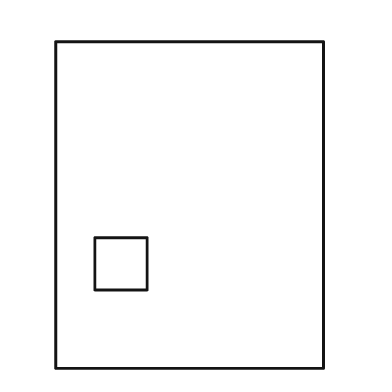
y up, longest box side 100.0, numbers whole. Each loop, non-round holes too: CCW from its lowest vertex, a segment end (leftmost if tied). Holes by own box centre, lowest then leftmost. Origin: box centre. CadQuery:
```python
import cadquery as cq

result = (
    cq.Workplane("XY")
    .moveTo(-41.0, -50.0)
    .lineTo(41.0, -50.0)
    .lineTo(41.0, 50.0)
    .lineTo(-41.0, 50.0)
    .close()
    .moveTo(-29.0, -26.0)
    .lineTo(-13.0, -26.0)
    .lineTo(-13.0, -10.0)
    .lineTo(-29.0, -10.0)
    .close()
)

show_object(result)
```